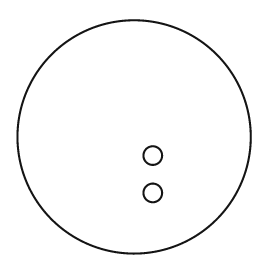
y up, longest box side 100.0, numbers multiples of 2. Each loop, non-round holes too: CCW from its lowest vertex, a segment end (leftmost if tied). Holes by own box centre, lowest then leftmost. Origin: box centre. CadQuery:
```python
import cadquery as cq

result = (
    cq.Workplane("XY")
    .moveTo(0.0, 0.0)
    .circle(50.0)
    .moveTo(8.0, -24.0)
    .circle(4.0)
    .moveTo(8.0, -8.0)
    .circle(4.0)
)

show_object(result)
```